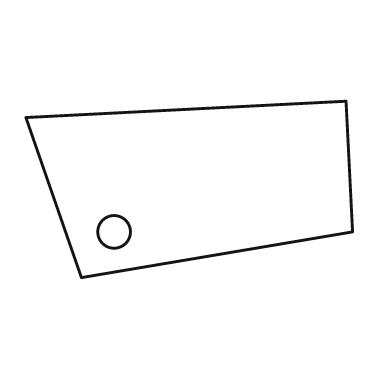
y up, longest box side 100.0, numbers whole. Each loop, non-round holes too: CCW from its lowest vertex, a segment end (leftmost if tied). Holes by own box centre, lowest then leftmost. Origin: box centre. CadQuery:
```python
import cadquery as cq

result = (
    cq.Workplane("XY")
    .moveTo(-33.0, -27.0)
    .lineTo(50.0, -13.0)
    .lineTo(48.0, 27.0)
    .lineTo(-50.0, 22.0)
    .close()
    .moveTo(-23.0, -13.0)
    .circle(5.0)
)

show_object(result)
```